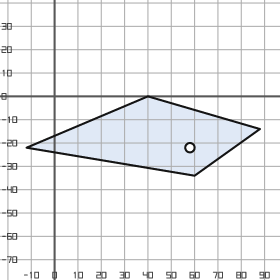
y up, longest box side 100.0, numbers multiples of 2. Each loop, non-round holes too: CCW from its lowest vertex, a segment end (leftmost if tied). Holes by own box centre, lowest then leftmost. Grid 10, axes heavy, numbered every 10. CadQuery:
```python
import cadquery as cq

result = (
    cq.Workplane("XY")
    .moveTo(60.0, -34.0)
    .lineTo(88.0, -14.0)
    .lineTo(40.0, 0.0)
    .lineTo(-12.0, -22.0)
    .close()
    .moveTo(58.0, -22.0)
    .circle(2.0)
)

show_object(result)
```